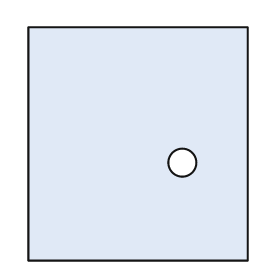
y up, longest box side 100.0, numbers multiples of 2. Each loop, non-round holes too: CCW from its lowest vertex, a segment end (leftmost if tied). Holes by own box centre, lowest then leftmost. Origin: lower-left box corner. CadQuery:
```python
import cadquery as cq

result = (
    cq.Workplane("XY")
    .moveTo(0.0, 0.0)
    .lineTo(94.0, 0.0)
    .lineTo(94.0, 100.0)
    .lineTo(0.0, 100.0)
    .close()
    .moveTo(66.0, 42.0)
    .circle(6.0)
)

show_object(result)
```